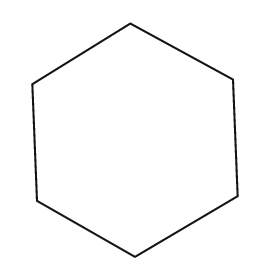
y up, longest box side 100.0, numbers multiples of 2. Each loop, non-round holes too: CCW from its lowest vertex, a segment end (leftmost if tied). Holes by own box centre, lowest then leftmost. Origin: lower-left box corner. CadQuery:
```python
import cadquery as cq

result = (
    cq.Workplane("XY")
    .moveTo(44.0, 0.0)
    .lineTo(88.0, 26.0)
    .lineTo(86.0, 76.0)
    .lineTo(42.0, 100.0)
    .lineTo(0.0, 74.0)
    .lineTo(2.0, 24.0)
    .close()
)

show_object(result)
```